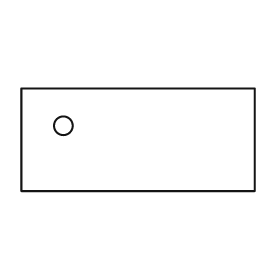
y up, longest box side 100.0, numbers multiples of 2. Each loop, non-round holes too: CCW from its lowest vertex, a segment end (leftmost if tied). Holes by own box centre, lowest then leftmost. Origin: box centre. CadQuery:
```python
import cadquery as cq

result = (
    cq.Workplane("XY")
    .moveTo(-50.0, -22.0)
    .lineTo(50.0, -22.0)
    .lineTo(50.0, 22.0)
    .lineTo(-50.0, 22.0)
    .close()
    .moveTo(-32.0, 6.0)
    .circle(4.0)
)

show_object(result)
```